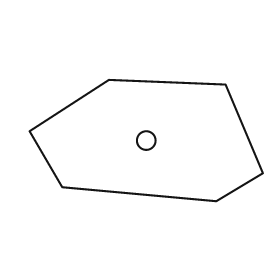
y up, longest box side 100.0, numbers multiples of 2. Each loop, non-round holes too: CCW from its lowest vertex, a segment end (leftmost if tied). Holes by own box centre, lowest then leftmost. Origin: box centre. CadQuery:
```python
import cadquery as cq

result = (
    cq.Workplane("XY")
    .moveTo(30.0, -26.0)
    .lineTo(50.0, -14.0)
    .lineTo(34.0, 24.0)
    .lineTo(-16.0, 26.0)
    .lineTo(-50.0, 4.0)
    .lineTo(-36.0, -20.0)
    .close()
    .moveTo(0.0, 0.0)
    .circle(4.0)
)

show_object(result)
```